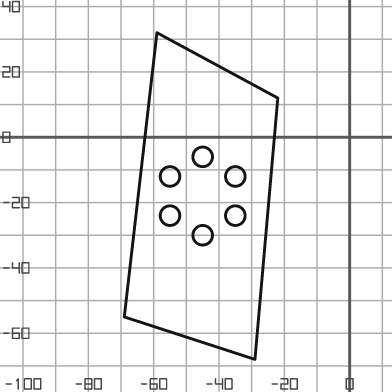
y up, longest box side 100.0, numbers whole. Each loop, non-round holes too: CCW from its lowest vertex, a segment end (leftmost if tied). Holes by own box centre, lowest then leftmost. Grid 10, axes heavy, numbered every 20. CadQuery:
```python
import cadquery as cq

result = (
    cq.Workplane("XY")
    .moveTo(-29.0, -68.0)
    .lineTo(-22.0, 12.0)
    .lineTo(-59.0, 32.0)
    .lineTo(-69.0, -55.0)
    .close()
    .moveTo(-45.0, -30.0)
    .circle(3.0)
    .moveTo(-55.0, -24.0)
    .circle(3.0)
    .moveTo(-35.0, -24.0)
    .circle(3.0)
    .moveTo(-55.0, -12.0)
    .circle(3.0)
    .moveTo(-35.0, -12.0)
    .circle(3.0)
    .moveTo(-45.0, -6.0)
    .circle(3.0)
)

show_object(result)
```